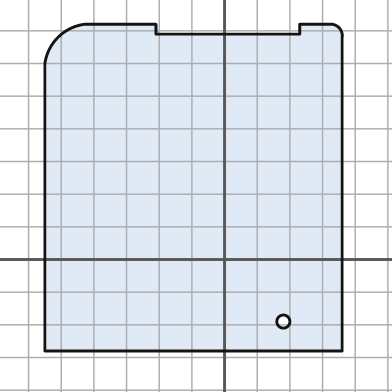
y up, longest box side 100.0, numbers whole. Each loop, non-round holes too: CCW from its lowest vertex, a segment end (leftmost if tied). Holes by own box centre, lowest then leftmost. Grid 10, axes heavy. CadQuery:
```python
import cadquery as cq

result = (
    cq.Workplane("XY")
    .moveTo(-55.0, -28.0)
    .lineTo(36.0, -28.0)
    .lineTo(36.0, 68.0)
    .threePointArc((35.0, 71.0), (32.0, 72.0))
    .lineTo(23.0, 72.0)
    .lineTo(23.0, 69.0)
    .lineTo(-21.0, 69.0)
    .lineTo(-21.0, 72.0)
    .lineTo(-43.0, 72.0)
    .threePointArc((-51.0, 68.0), (-55.0, 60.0))
    .close()
    .moveTo(18.0, -19.0)
    .circle(2.0)
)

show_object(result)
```